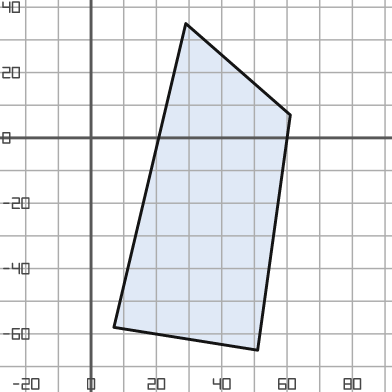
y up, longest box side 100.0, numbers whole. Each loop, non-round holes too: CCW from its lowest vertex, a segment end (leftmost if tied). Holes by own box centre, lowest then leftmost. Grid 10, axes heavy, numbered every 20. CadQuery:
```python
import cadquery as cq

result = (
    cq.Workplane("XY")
    .moveTo(51.0, -65.0)
    .lineTo(61.0, 7.0)
    .lineTo(29.0, 35.0)
    .lineTo(7.0, -58.0)
    .close()
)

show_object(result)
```